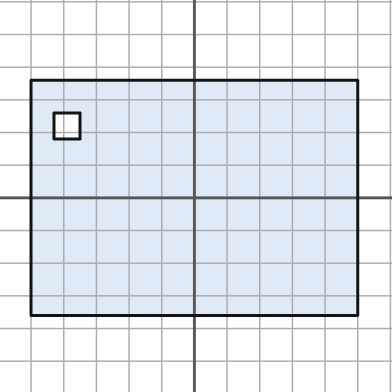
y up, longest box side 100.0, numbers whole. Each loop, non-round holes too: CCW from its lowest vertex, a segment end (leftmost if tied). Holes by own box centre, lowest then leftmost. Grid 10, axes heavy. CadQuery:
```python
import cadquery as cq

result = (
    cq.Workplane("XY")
    .moveTo(-50.0, -36.0)
    .lineTo(50.0, -36.0)
    .lineTo(50.0, 36.0)
    .lineTo(-50.0, 36.0)
    .close()
    .moveTo(-43.0, 18.0)
    .lineTo(-35.0, 18.0)
    .lineTo(-35.0, 26.0)
    .lineTo(-43.0, 26.0)
    .close()
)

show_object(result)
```